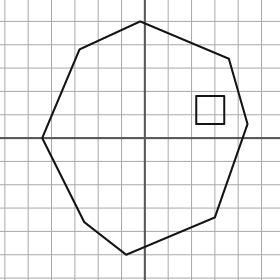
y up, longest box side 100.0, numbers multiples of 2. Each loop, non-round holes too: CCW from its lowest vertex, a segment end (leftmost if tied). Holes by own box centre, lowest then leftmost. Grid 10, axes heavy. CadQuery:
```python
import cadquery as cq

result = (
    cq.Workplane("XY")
    .moveTo(-8.0, -50.0)
    .lineTo(30.0, -34.0)
    .lineTo(44.0, 6.0)
    .lineTo(36.0, 34.0)
    .lineTo(-2.0, 50.0)
    .lineTo(-28.0, 38.0)
    .lineTo(-44.0, 0.0)
    .lineTo(-26.0, -36.0)
    .close()
    .moveTo(22.0, 6.0)
    .lineTo(34.0, 6.0)
    .lineTo(34.0, 18.0)
    .lineTo(22.0, 18.0)
    .close()
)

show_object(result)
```